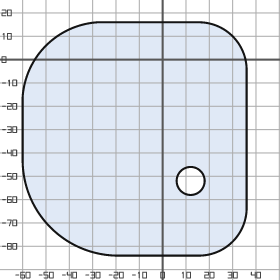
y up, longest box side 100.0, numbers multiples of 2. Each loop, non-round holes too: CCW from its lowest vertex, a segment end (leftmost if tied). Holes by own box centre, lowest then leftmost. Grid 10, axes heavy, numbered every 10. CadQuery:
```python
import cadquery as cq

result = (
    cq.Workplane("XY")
    .moveTo(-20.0, -84.0)
    .lineTo(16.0, -84.0)
    .threePointArc((30.0, -78.0), (36.0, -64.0))
    .lineTo(36.0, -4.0)
    .threePointArc((30.0, 10.0), (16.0, 16.0))
    .lineTo(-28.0, 16.0)
    .threePointArc((-50.0, 6.0), (-60.0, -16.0))
    .lineTo(-60.0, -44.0)
    .threePointArc((-48.0, -72.0), (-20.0, -84.0))
    .close()
    .moveTo(12.0, -52.0)
    .circle(6.0)
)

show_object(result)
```